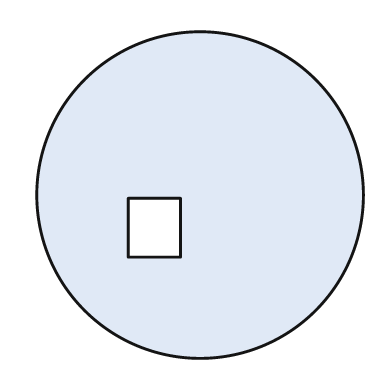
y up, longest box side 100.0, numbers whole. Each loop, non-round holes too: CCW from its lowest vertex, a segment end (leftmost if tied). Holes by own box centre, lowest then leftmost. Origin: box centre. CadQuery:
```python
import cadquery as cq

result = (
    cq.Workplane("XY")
    .moveTo(0.0, 0.0)
    .circle(50.0)
    .moveTo(-22.0, -19.0)
    .lineTo(-6.0, -19.0)
    .lineTo(-6.0, -1.0)
    .lineTo(-22.0, -1.0)
    .close()
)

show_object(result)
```